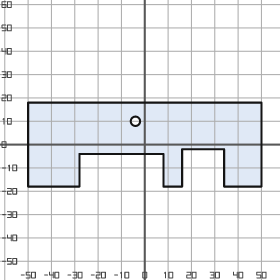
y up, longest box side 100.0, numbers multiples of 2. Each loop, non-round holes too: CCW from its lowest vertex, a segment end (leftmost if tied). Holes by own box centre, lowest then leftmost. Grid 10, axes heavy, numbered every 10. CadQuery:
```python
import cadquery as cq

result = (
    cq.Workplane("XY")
    .moveTo(-50.0, -18.0)
    .lineTo(-28.0, -18.0)
    .lineTo(-28.0, -4.0)
    .lineTo(8.0, -4.0)
    .lineTo(8.0, -18.0)
    .lineTo(16.0, -18.0)
    .lineTo(16.0, -2.0)
    .lineTo(34.0, -2.0)
    .lineTo(34.0, -18.0)
    .lineTo(50.0, -18.0)
    .lineTo(50.0, 18.0)
    .lineTo(-50.0, 18.0)
    .close()
    .moveTo(-4.0, 10.0)
    .circle(2.0)
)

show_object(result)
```